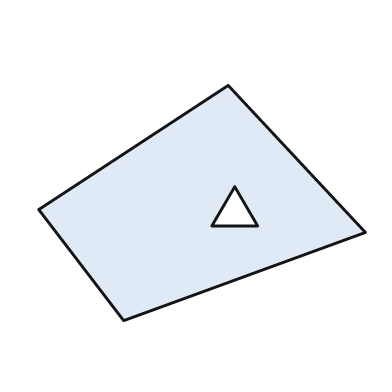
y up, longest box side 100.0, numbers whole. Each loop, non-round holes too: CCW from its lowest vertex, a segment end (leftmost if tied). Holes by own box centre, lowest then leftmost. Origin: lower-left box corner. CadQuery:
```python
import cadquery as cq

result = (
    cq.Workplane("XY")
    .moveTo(26.0, 0.0)
    .lineTo(100.0, 27.0)
    .lineTo(58.0, 72.0)
    .lineTo(0.0, 34.0)
    .close()
    .moveTo(53.0, 29.0)
    .lineTo(67.0, 29.0)
    .lineTo(60.0, 41.0)
    .close()
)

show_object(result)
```